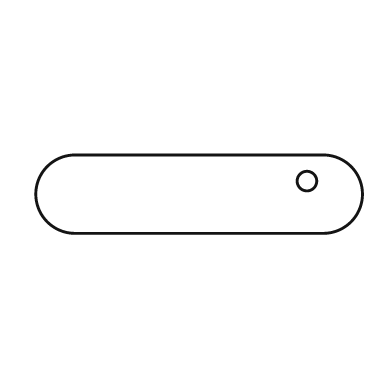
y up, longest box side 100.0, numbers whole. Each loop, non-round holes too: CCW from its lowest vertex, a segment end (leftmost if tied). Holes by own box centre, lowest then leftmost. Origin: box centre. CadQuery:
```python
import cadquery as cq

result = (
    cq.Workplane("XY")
    .moveTo(-38.0, -12.0)
    .lineTo(38.0, -12.0)
    .threePointArc((50.0, 0.0), (38.0, 12.0))
    .lineTo(-38.0, 12.0)
    .threePointArc((-50.0, 0.0), (-38.0, -12.0))
    .close()
    .moveTo(33.0, 4.0)
    .circle(3.0)
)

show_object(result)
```